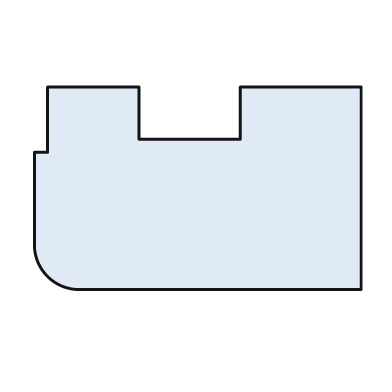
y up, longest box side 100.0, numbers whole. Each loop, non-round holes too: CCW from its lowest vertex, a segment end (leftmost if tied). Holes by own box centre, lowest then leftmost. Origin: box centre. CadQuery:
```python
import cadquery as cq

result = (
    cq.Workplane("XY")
    .moveTo(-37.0, -31.0)
    .lineTo(50.0, -31.0)
    .lineTo(50.0, 31.0)
    .lineTo(13.0, 31.0)
    .lineTo(13.0, 15.0)
    .lineTo(-18.0, 15.0)
    .lineTo(-18.0, 31.0)
    .lineTo(-46.0, 31.0)
    .lineTo(-46.0, 11.0)
    .lineTo(-50.0, 11.0)
    .lineTo(-50.0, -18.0)
    .threePointArc((-46.0, -27.0), (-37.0, -31.0))
    .close()
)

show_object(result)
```